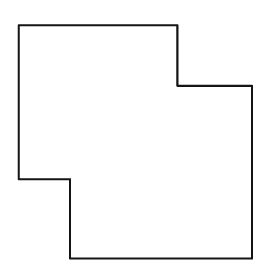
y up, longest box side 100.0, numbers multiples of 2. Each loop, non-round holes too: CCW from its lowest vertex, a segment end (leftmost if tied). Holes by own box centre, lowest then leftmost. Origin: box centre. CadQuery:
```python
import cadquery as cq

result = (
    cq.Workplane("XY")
    .moveTo(-28.0, -50.0)
    .lineTo(50.0, -50.0)
    .lineTo(50.0, 24.0)
    .lineTo(18.0, 24.0)
    .lineTo(18.0, 50.0)
    .lineTo(-50.0, 50.0)
    .lineTo(-50.0, -16.0)
    .lineTo(-28.0, -16.0)
    .close()
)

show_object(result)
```